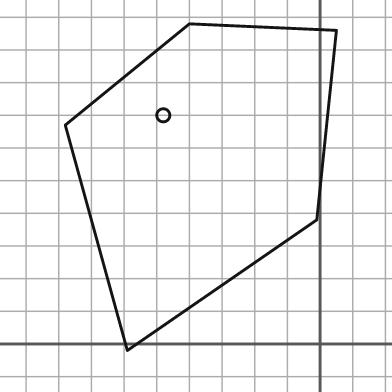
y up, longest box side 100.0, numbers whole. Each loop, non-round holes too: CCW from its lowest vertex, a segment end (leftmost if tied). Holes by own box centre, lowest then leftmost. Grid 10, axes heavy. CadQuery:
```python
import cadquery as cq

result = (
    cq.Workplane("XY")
    .moveTo(-59.0, -2.0)
    .lineTo(-1.0, 38.0)
    .lineTo(5.0, 96.0)
    .lineTo(-40.0, 98.0)
    .lineTo(-78.0, 67.0)
    .close()
    .moveTo(-48.0, 70.0)
    .circle(2.0)
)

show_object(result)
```